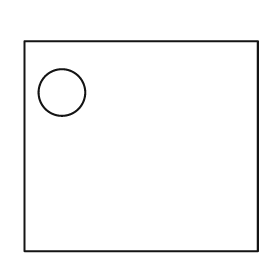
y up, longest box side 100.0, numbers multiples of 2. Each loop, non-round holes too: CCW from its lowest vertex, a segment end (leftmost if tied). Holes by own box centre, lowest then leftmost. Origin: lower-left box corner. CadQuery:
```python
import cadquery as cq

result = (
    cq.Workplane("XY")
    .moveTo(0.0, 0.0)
    .lineTo(100.0, 0.0)
    .lineTo(100.0, 90.0)
    .lineTo(0.0, 90.0)
    .close()
    .moveTo(16.0, 68.0)
    .circle(10.0)
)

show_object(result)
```